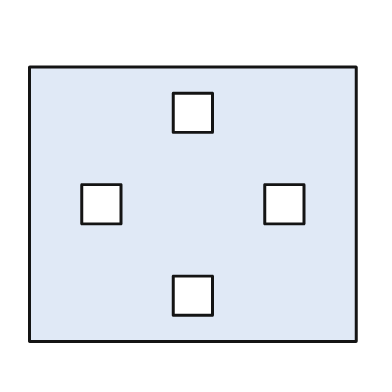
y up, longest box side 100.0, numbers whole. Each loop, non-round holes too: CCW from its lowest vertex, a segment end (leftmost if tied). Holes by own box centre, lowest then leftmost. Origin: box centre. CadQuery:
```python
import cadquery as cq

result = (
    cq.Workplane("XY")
    .moveTo(-50.0, -42.0)
    .lineTo(50.0, -42.0)
    .lineTo(50.0, 42.0)
    .lineTo(-50.0, 42.0)
    .close()
    .moveTo(-6.0, -34.0)
    .lineTo(6.0, -34.0)
    .lineTo(6.0, -22.0)
    .lineTo(-6.0, -22.0)
    .close()
    .moveTo(-34.0, -6.0)
    .lineTo(-22.0, -6.0)
    .lineTo(-22.0, 6.0)
    .lineTo(-34.0, 6.0)
    .close()
    .moveTo(22.0, -6.0)
    .lineTo(34.0, -6.0)
    .lineTo(34.0, 6.0)
    .lineTo(22.0, 6.0)
    .close()
    .moveTo(-6.0, 22.0)
    .lineTo(6.0, 22.0)
    .lineTo(6.0, 34.0)
    .lineTo(-6.0, 34.0)
    .close()
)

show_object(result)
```